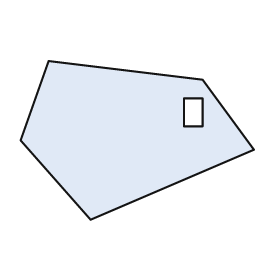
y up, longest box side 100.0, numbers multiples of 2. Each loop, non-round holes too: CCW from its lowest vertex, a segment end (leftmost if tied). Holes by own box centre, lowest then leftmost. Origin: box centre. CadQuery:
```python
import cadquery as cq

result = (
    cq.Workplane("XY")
    .moveTo(-20.0, -34.0)
    .lineTo(50.0, -4.0)
    .lineTo(28.0, 26.0)
    .lineTo(-38.0, 34.0)
    .lineTo(-50.0, 0.0)
    .close()
    .moveTo(20.0, 6.0)
    .lineTo(28.0, 6.0)
    .lineTo(28.0, 18.0)
    .lineTo(20.0, 18.0)
    .close()
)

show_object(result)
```